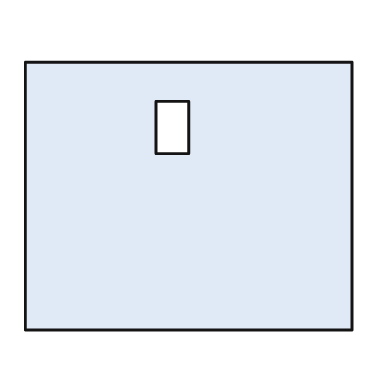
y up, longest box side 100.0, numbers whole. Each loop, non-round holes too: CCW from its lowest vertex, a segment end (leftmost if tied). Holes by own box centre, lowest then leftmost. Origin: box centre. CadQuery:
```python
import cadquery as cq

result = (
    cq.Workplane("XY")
    .moveTo(-50.0, -41.0)
    .lineTo(50.0, -41.0)
    .lineTo(50.0, 41.0)
    .lineTo(-50.0, 41.0)
    .close()
    .moveTo(-10.0, 13.0)
    .lineTo(0.0, 13.0)
    .lineTo(0.0, 29.0)
    .lineTo(-10.0, 29.0)
    .close()
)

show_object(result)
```